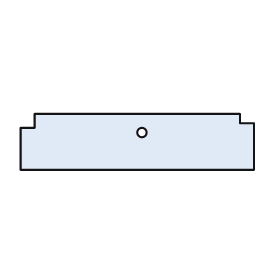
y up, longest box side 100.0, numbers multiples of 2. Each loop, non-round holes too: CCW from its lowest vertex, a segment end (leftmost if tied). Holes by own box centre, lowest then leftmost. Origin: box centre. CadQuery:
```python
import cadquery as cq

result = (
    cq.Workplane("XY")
    .moveTo(-50.0, -12.0)
    .lineTo(50.0, -12.0)
    .lineTo(50.0, 8.0)
    .lineTo(44.0, 8.0)
    .lineTo(44.0, 12.0)
    .lineTo(-44.0, 12.0)
    .lineTo(-44.0, 6.0)
    .lineTo(-50.0, 6.0)
    .close()
    .moveTo(2.0, 4.0)
    .circle(2.0)
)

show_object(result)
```